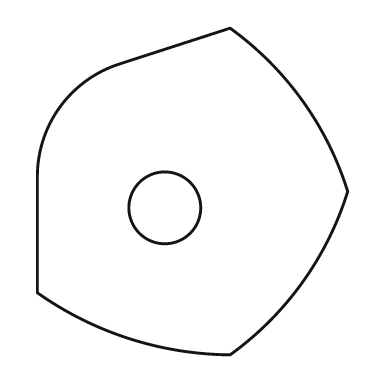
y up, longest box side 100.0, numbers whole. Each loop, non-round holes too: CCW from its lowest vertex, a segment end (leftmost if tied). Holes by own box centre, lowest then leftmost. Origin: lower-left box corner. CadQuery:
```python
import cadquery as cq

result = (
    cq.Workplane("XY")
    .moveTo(59.0, 0.0)
    .threePointArc((81.0, 22.0), (95.0, 50.0))
    .threePointArc((81.0, 78.0), (59.0, 100.0))
    .lineTo(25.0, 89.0)
    .threePointArc((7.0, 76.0), (0.0, 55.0))
    .lineTo(0.0, 19.0)
    .threePointArc((28.0, 5.0), (59.0, 0.0))
    .close()
    .moveTo(39.0, 45.0)
    .circle(11.0)
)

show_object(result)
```